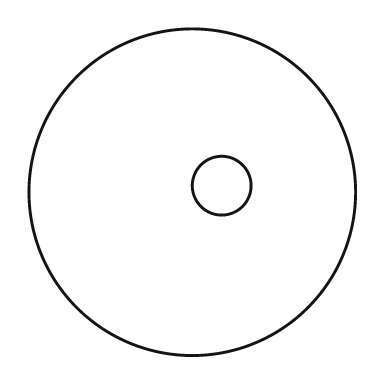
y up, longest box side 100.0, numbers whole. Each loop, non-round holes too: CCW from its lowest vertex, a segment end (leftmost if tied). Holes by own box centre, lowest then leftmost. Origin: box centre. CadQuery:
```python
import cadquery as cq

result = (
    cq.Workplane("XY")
    .moveTo(0.0, 0.0)
    .circle(50.0)
    .moveTo(9.0, 2.0)
    .circle(9.0)
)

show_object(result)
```